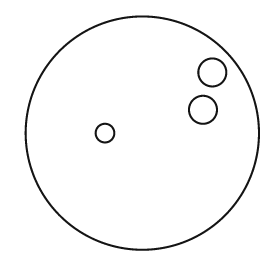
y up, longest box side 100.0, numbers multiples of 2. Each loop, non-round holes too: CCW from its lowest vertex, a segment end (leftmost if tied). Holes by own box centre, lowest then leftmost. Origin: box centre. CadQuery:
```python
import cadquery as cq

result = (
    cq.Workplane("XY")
    .moveTo(0.0, 0.0)
    .circle(50.0)
    .moveTo(-16.0, 0.0)
    .circle(4.0)
    .moveTo(26.0, 10.0)
    .circle(6.0)
    .moveTo(30.0, 26.0)
    .circle(6.0)
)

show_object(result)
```